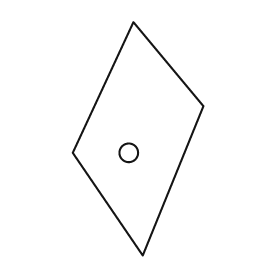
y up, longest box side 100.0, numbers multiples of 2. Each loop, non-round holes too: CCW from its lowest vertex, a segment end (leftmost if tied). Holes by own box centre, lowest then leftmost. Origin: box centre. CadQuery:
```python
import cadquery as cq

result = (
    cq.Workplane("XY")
    .moveTo(2.0, -50.0)
    .lineTo(28.0, 14.0)
    .lineTo(-2.0, 50.0)
    .lineTo(-28.0, -6.0)
    .close()
    .moveTo(-4.0, -6.0)
    .circle(4.0)
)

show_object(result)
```